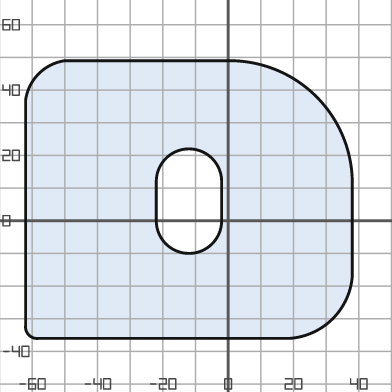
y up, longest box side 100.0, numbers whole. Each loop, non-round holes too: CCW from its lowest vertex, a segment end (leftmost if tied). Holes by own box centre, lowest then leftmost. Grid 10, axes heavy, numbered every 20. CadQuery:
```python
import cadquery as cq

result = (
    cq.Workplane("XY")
    .moveTo(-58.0, -36.0)
    .lineTo(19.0, -36.0)
    .threePointArc((32.0, -30.0), (38.0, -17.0))
    .lineTo(38.0, 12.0)
    .threePointArc((27.0, 38.0), (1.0, 49.0))
    .lineTo(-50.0, 49.0)
    .threePointArc((-58.0, 45.0), (-62.0, 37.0))
    .lineTo(-62.0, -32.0)
    .threePointArc((-61.0, -35.0), (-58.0, -36.0))
    .close()
    .moveTo(-22.0, 0.0)
    .threePointArc((-12.0, -10.0), (-2.0, 0.0))
    .lineTo(-2.0, 12.0)
    .threePointArc((-12.0, 22.0), (-22.0, 12.0))
    .close()
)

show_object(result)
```